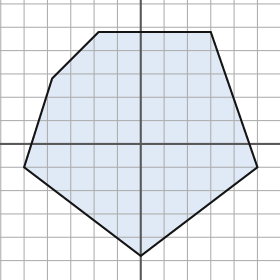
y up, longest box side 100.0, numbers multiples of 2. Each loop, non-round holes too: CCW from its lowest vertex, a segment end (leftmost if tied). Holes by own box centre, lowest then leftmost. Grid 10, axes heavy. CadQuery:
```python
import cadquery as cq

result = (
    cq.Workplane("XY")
    .moveTo(0.0, -48.0)
    .lineTo(50.0, -10.0)
    .lineTo(30.0, 48.0)
    .lineTo(-18.0, 48.0)
    .lineTo(-38.0, 28.0)
    .lineTo(-50.0, -10.0)
    .close()
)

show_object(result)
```